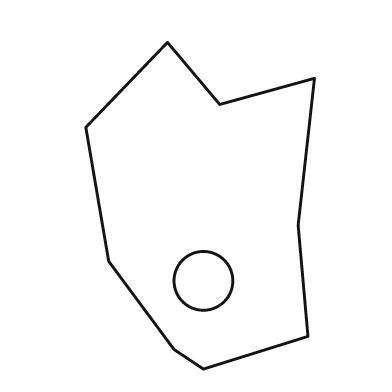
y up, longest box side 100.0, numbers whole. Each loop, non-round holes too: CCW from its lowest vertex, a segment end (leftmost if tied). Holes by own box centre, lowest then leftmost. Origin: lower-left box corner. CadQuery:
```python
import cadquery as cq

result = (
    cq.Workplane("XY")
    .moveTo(36.0, 0.0)
    .lineTo(68.0, 10.0)
    .lineTo(65.0, 44.0)
    .lineTo(70.0, 89.0)
    .lineTo(41.0, 81.0)
    .lineTo(25.0, 100.0)
    .lineTo(0.0, 74.0)
    .lineTo(7.0, 33.0)
    .lineTo(27.0, 6.0)
    .close()
    .moveTo(36.0, 27.0)
    .circle(9.0)
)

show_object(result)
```